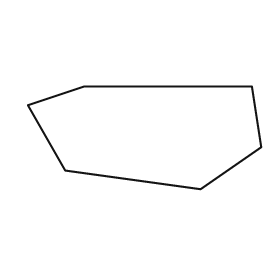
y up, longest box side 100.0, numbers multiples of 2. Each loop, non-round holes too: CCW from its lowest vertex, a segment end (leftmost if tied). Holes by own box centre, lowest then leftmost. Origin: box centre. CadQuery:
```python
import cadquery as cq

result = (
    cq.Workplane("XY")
    .moveTo(24.0, -22.0)
    .lineTo(50.0, -4.0)
    .lineTo(46.0, 22.0)
    .lineTo(-26.0, 22.0)
    .lineTo(-50.0, 14.0)
    .lineTo(-34.0, -14.0)
    .close()
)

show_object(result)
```